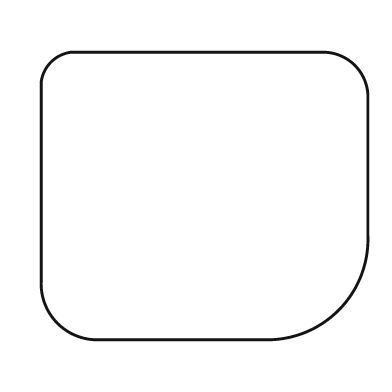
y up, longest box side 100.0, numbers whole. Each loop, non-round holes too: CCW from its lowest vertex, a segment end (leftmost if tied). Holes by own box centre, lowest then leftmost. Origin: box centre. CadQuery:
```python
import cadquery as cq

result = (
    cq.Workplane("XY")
    .moveTo(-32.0, -44.0)
    .lineTo(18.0, -44.0)
    .threePointArc((41.0, -35.0), (50.0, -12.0))
    .lineTo(50.0, 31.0)
    .threePointArc((46.0, 40.0), (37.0, 44.0))
    .lineTo(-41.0, 44.0)
    .threePointArc((-47.0, 41.0), (-50.0, 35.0))
    .lineTo(-50.0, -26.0)
    .threePointArc((-45.0, -39.0), (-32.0, -44.0))
    .close()
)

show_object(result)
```